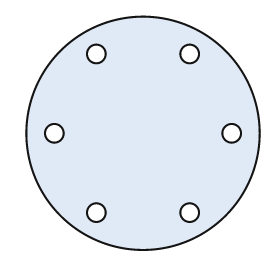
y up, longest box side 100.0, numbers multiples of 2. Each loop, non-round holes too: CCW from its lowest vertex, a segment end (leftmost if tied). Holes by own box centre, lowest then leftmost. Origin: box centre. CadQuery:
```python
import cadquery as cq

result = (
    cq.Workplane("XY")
    .moveTo(0.0, 0.0)
    .circle(50.0)
    .moveTo(-20.0, -34.0)
    .circle(4.0)
    .moveTo(20.0, -34.0)
    .circle(4.0)
    .moveTo(-38.0, 0.0)
    .circle(4.0)
    .moveTo(38.0, 0.0)
    .circle(4.0)
    .moveTo(-20.0, 34.0)
    .circle(4.0)
    .moveTo(20.0, 34.0)
    .circle(4.0)
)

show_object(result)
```